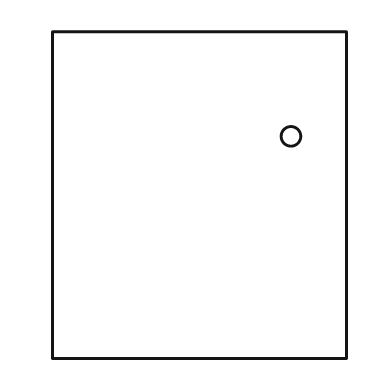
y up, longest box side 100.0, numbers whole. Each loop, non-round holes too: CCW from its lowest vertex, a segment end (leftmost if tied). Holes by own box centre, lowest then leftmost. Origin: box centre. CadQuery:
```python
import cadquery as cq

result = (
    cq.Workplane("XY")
    .moveTo(-45.0, -50.0)
    .lineTo(45.0, -50.0)
    .lineTo(45.0, 50.0)
    .lineTo(-45.0, 50.0)
    .close()
    .moveTo(28.0, 18.0)
    .circle(3.0)
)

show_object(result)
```